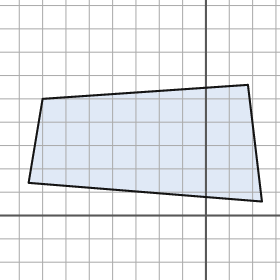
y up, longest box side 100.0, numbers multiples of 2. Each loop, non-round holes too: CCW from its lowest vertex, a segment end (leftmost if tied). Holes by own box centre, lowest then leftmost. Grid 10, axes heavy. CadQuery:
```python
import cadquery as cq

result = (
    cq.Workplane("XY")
    .moveTo(24.0, 6.0)
    .lineTo(18.0, 56.0)
    .lineTo(-70.0, 50.0)
    .lineTo(-76.0, 14.0)
    .close()
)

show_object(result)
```